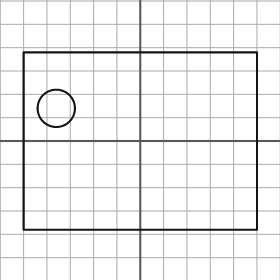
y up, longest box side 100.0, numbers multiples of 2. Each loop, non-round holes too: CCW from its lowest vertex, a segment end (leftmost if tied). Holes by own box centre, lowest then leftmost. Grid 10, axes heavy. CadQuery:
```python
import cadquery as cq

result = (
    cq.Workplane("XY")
    .moveTo(-50.0, -38.0)
    .lineTo(50.0, -38.0)
    .lineTo(50.0, 38.0)
    .lineTo(-50.0, 38.0)
    .close()
    .moveTo(-36.0, 14.0)
    .circle(8.0)
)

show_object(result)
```